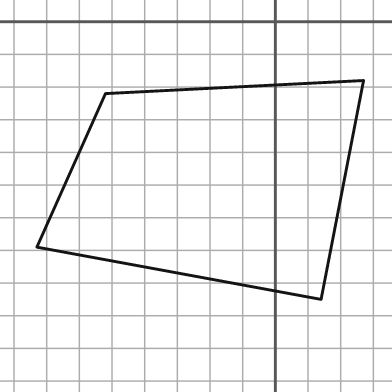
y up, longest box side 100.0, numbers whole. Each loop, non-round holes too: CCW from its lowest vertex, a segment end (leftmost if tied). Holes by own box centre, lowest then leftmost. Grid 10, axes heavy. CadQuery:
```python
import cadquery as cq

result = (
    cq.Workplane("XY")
    .moveTo(14.0, -85.0)
    .lineTo(27.0, -18.0)
    .lineTo(-52.0, -22.0)
    .lineTo(-73.0, -69.0)
    .close()
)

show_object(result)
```